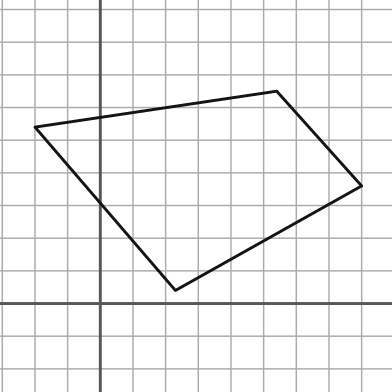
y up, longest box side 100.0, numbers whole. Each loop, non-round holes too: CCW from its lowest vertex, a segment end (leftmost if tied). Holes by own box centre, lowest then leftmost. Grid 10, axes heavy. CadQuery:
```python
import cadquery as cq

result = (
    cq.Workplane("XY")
    .moveTo(23.0, 4.0)
    .lineTo(80.0, 36.0)
    .lineTo(54.0, 65.0)
    .lineTo(-20.0, 54.0)
    .close()
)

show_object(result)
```